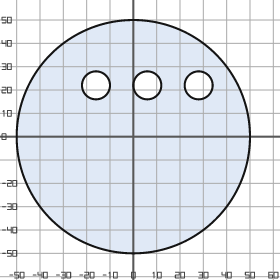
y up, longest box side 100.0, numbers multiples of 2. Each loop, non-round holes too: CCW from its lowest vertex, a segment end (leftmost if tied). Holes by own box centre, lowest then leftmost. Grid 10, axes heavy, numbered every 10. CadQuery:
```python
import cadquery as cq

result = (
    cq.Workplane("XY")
    .moveTo(0.0, 0.0)
    .circle(50.0)
    .moveTo(-16.0, 22.0)
    .circle(6.0)
    .moveTo(6.0, 22.0)
    .circle(6.0)
    .moveTo(28.0, 22.0)
    .circle(6.0)
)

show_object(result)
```